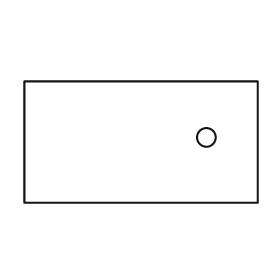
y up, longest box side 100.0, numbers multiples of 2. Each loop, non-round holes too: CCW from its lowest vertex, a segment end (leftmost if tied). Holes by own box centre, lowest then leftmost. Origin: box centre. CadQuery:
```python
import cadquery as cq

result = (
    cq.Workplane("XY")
    .moveTo(-50.0, -26.0)
    .lineTo(50.0, -26.0)
    .lineTo(50.0, 26.0)
    .lineTo(-50.0, 26.0)
    .close()
    .moveTo(28.0, 2.0)
    .circle(4.0)
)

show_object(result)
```